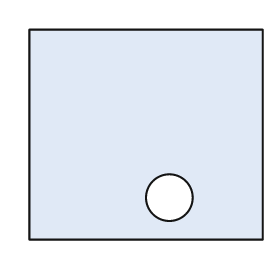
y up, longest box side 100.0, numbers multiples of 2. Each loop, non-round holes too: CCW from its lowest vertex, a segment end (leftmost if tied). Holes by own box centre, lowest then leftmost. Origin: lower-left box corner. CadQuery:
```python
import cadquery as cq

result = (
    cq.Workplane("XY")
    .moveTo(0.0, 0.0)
    .lineTo(100.0, 0.0)
    .lineTo(100.0, 90.0)
    .lineTo(0.0, 90.0)
    .close()
    .moveTo(60.0, 18.0)
    .circle(10.0)
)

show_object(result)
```